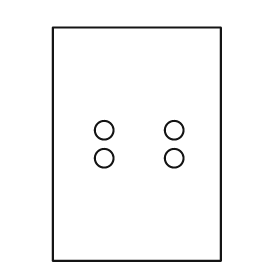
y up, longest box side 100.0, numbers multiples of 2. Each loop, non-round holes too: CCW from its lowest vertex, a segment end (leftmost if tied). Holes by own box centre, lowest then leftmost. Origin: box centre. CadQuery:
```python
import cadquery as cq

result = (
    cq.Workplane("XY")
    .moveTo(-36.0, -50.0)
    .lineTo(36.0, -50.0)
    .lineTo(36.0, 50.0)
    .lineTo(-36.0, 50.0)
    .close()
    .moveTo(-14.0, -6.0)
    .circle(4.0)
    .moveTo(16.0, -6.0)
    .circle(4.0)
    .moveTo(-14.0, 6.0)
    .circle(4.0)
    .moveTo(16.0, 6.0)
    .circle(4.0)
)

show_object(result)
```